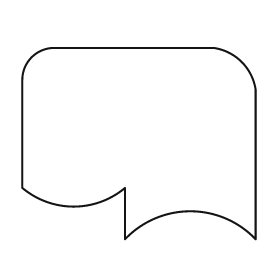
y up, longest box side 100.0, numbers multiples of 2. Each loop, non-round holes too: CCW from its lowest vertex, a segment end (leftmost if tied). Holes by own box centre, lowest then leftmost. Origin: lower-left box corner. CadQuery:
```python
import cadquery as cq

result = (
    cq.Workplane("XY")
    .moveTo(44.0, 0.0)
    .threePointArc((72.0, 12.0), (100.0, 0.0))
    .lineTo(100.0, 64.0)
    .threePointArc((94.0, 76.0), (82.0, 82.0))
    .lineTo(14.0, 82.0)
    .threePointArc((4.0, 78.0), (0.0, 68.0))
    .lineTo(0.0, 22.0)
    .threePointArc((22.0, 14.0), (44.0, 22.0))
    .close()
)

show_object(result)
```